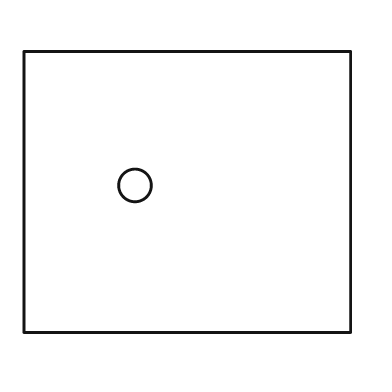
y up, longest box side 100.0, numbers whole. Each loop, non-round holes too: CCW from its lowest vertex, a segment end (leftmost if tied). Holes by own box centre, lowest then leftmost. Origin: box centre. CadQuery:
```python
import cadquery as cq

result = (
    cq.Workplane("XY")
    .moveTo(-50.0, -43.0)
    .lineTo(50.0, -43.0)
    .lineTo(50.0, 43.0)
    .lineTo(-50.0, 43.0)
    .close()
    .moveTo(-16.0, 2.0)
    .circle(5.0)
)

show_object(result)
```